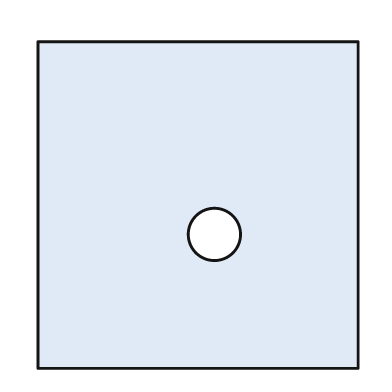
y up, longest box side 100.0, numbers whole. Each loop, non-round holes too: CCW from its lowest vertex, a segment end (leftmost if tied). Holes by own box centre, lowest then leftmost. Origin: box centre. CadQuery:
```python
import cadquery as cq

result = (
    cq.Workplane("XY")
    .moveTo(-49.0, -50.0)
    .lineTo(49.0, -50.0)
    .lineTo(49.0, 50.0)
    .lineTo(-49.0, 50.0)
    .close()
    .moveTo(5.0, -9.0)
    .circle(8.0)
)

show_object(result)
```